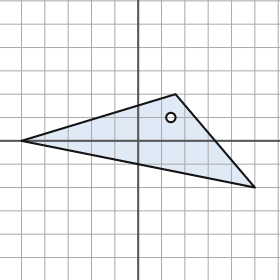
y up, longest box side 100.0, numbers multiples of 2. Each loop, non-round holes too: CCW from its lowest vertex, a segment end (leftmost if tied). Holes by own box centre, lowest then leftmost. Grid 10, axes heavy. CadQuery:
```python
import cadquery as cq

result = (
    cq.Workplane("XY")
    .moveTo(50.0, -20.0)
    .lineTo(16.0, 20.0)
    .lineTo(-50.0, 0.0)
    .close()
    .moveTo(14.0, 10.0)
    .circle(2.0)
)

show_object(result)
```